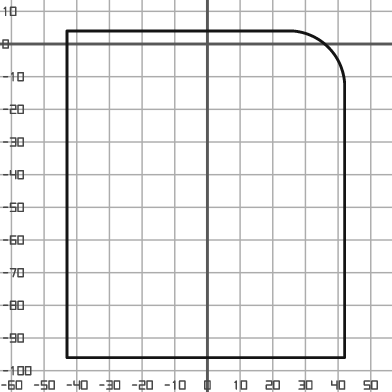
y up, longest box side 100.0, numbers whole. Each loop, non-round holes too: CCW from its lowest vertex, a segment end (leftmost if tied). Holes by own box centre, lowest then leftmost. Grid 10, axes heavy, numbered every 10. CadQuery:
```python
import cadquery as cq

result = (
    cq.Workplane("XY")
    .moveTo(-43.0, -96.0)
    .lineTo(42.0, -96.0)
    .lineTo(42.0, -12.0)
    .threePointArc((37.0, -1.0), (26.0, 4.0))
    .lineTo(-43.0, 4.0)
    .close()
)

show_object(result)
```